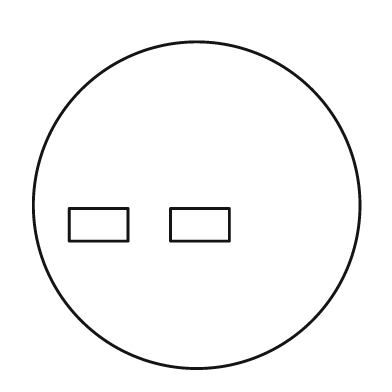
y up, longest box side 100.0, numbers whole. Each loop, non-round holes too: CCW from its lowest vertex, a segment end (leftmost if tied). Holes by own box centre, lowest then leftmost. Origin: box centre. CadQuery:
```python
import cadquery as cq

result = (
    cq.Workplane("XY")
    .moveTo(0.0, 0.0)
    .circle(50.0)
    .moveTo(-39.0, -11.0)
    .lineTo(-21.0, -11.0)
    .lineTo(-21.0, -1.0)
    .lineTo(-39.0, -1.0)
    .close()
    .moveTo(-8.0, -11.0)
    .lineTo(10.0, -11.0)
    .lineTo(10.0, -1.0)
    .lineTo(-8.0, -1.0)
    .close()
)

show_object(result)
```